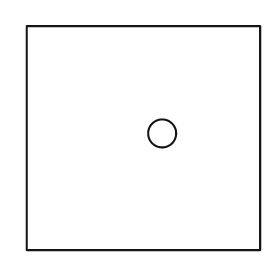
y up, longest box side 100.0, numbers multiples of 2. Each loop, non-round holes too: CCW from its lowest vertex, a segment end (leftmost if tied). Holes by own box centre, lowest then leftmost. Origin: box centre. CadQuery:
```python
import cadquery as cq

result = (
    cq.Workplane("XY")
    .moveTo(-50.0, -48.0)
    .lineTo(50.0, -48.0)
    .lineTo(50.0, 48.0)
    .lineTo(-50.0, 48.0)
    .close()
    .moveTo(8.0, 2.0)
    .circle(6.0)
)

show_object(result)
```